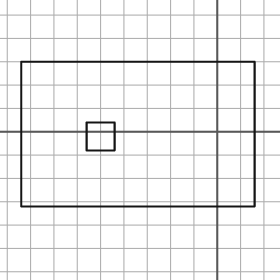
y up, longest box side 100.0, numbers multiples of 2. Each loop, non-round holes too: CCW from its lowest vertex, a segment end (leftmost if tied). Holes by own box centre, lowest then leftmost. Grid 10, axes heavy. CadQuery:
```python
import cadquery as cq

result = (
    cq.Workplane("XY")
    .moveTo(-84.0, -32.0)
    .lineTo(16.0, -32.0)
    .lineTo(16.0, 30.0)
    .lineTo(-84.0, 30.0)
    .close()
    .moveTo(-56.0, -8.0)
    .lineTo(-44.0, -8.0)
    .lineTo(-44.0, 4.0)
    .lineTo(-56.0, 4.0)
    .close()
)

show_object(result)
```